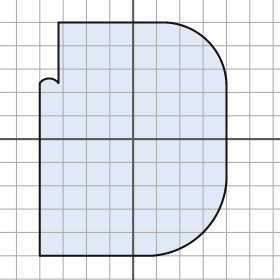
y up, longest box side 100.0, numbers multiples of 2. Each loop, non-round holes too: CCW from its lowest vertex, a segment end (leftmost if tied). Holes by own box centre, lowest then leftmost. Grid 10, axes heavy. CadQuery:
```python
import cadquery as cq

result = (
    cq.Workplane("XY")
    .moveTo(-40.0, -50.0)
    .lineTo(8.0, -50.0)
    .threePointArc((30.0, -40.0), (40.0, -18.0))
    .lineTo(40.0, 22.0)
    .threePointArc((32.0, 42.0), (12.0, 50.0))
    .lineTo(-32.0, 50.0)
    .lineTo(-32.0, 24.0)
    .threePointArc((-36.0, 26.0), (-40.0, 24.0))
    .close()
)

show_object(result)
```